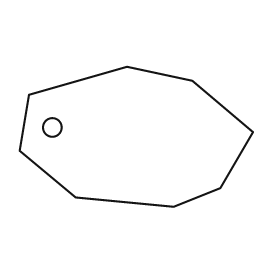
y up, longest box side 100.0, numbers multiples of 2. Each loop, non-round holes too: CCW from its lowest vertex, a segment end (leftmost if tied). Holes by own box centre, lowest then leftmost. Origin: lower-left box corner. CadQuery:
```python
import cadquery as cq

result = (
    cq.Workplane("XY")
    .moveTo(66.0, 0.0)
    .lineTo(86.0, 8.0)
    .lineTo(100.0, 32.0)
    .lineTo(74.0, 54.0)
    .lineTo(46.0, 60.0)
    .lineTo(4.0, 48.0)
    .lineTo(0.0, 24.0)
    .lineTo(24.0, 4.0)
    .close()
    .moveTo(14.0, 34.0)
    .circle(4.0)
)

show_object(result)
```